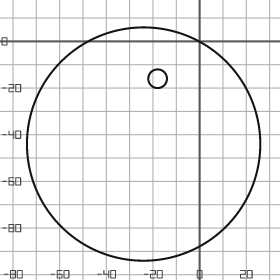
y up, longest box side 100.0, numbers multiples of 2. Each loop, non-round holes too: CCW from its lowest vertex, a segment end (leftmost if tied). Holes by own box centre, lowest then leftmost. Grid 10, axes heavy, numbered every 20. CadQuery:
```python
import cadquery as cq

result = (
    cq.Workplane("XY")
    .moveTo(-24.0, -44.0)
    .circle(50.0)
    .moveTo(-18.0, -16.0)
    .circle(4.0)
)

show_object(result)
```